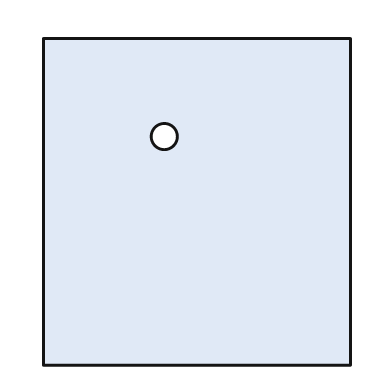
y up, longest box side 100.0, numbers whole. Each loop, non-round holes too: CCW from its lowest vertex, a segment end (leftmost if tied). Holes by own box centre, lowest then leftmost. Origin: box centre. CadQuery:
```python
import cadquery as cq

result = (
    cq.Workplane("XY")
    .moveTo(-47.0, -50.0)
    .lineTo(47.0, -50.0)
    .lineTo(47.0, 50.0)
    .lineTo(-47.0, 50.0)
    .close()
    .moveTo(-10.0, 20.0)
    .circle(4.0)
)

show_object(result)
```